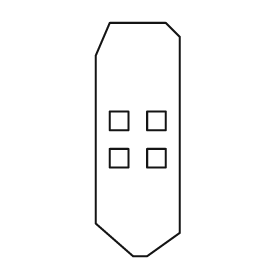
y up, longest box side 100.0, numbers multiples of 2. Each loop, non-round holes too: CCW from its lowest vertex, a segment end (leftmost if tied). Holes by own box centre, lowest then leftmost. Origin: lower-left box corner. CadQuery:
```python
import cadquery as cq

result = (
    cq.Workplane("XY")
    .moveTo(16.0, 0.0)
    .lineTo(22.0, 0.0)
    .lineTo(36.0, 10.0)
    .lineTo(36.0, 94.0)
    .lineTo(30.0, 100.0)
    .lineTo(6.0, 100.0)
    .lineTo(0.0, 86.0)
    .lineTo(0.0, 14.0)
    .close()
    .moveTo(6.0, 38.0)
    .lineTo(14.0, 38.0)
    .lineTo(14.0, 46.0)
    .lineTo(6.0, 46.0)
    .close()
    .moveTo(22.0, 38.0)
    .lineTo(30.0, 38.0)
    .lineTo(30.0, 46.0)
    .lineTo(22.0, 46.0)
    .close()
    .moveTo(6.0, 54.0)
    .lineTo(14.0, 54.0)
    .lineTo(14.0, 62.0)
    .lineTo(6.0, 62.0)
    .close()
    .moveTo(22.0, 54.0)
    .lineTo(30.0, 54.0)
    .lineTo(30.0, 62.0)
    .lineTo(22.0, 62.0)
    .close()
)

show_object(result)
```